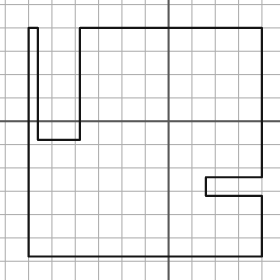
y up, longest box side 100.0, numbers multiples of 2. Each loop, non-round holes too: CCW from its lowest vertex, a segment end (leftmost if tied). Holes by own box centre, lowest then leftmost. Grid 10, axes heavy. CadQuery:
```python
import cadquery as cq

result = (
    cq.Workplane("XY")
    .moveTo(-60.0, -58.0)
    .lineTo(40.0, -58.0)
    .lineTo(40.0, -32.0)
    .lineTo(16.0, -32.0)
    .lineTo(16.0, -24.0)
    .lineTo(40.0, -24.0)
    .lineTo(40.0, 40.0)
    .lineTo(-38.0, 40.0)
    .lineTo(-38.0, -8.0)
    .lineTo(-56.0, -8.0)
    .lineTo(-56.0, 40.0)
    .lineTo(-60.0, 40.0)
    .close()
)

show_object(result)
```